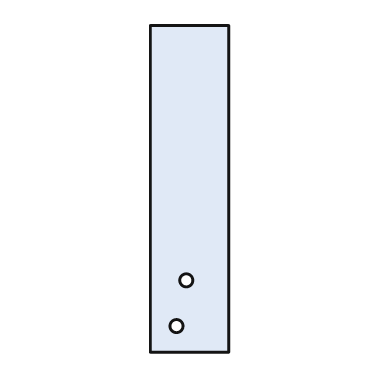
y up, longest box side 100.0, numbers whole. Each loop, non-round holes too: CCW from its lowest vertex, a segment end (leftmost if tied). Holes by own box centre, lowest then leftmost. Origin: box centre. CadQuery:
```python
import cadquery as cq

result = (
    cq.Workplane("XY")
    .moveTo(-12.0, -50.0)
    .lineTo(12.0, -50.0)
    .lineTo(12.0, 50.0)
    .lineTo(-12.0, 50.0)
    .close()
    .moveTo(-4.0, -42.0)
    .circle(2.0)
    .moveTo(-1.0, -28.0)
    .circle(2.0)
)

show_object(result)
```